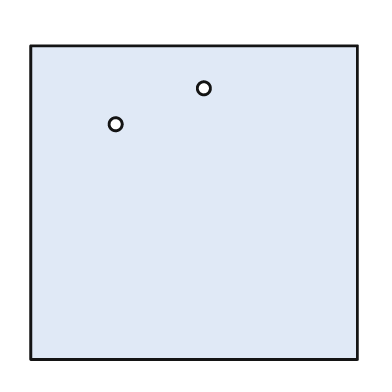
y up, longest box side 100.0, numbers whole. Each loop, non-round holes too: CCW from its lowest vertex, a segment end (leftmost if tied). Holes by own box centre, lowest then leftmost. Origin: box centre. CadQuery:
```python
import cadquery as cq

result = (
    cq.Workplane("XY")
    .moveTo(-50.0, -48.0)
    .lineTo(50.0, -48.0)
    .lineTo(50.0, 48.0)
    .lineTo(-50.0, 48.0)
    .close()
    .moveTo(-24.0, 24.0)
    .circle(2.0)
    .moveTo(3.0, 35.0)
    .circle(2.0)
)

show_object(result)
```